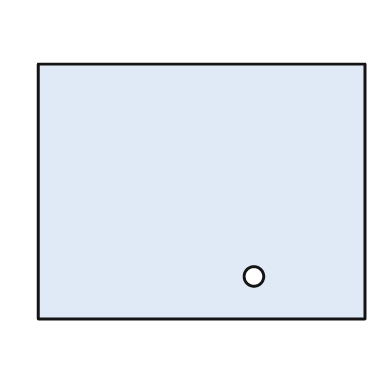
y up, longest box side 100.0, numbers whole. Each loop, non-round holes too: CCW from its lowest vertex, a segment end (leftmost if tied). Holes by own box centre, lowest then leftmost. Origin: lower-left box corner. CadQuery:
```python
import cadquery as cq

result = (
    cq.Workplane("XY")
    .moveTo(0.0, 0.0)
    .lineTo(100.0, 0.0)
    .lineTo(100.0, 78.0)
    .lineTo(0.0, 78.0)
    .close()
    .moveTo(66.0, 13.0)
    .circle(3.0)
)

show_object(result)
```